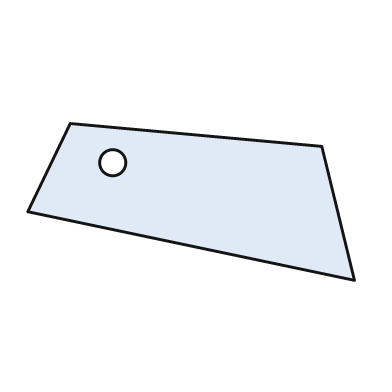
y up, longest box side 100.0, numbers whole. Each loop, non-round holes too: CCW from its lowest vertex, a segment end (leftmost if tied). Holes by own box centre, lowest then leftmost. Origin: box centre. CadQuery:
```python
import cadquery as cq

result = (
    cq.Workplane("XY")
    .moveTo(50.0, -24.0)
    .lineTo(40.0, 17.0)
    .lineTo(-37.0, 24.0)
    .lineTo(-50.0, -3.0)
    .close()
    .moveTo(-24.0, 12.0)
    .circle(4.0)
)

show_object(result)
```